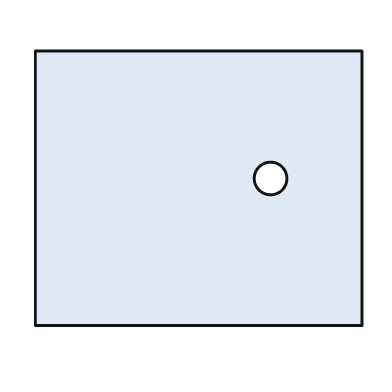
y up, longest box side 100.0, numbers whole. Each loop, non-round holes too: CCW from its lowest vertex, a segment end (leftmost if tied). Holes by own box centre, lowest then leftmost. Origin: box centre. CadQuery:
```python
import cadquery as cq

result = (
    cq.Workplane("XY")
    .moveTo(-50.0, -42.0)
    .lineTo(50.0, -42.0)
    .lineTo(50.0, 42.0)
    .lineTo(-50.0, 42.0)
    .close()
    .moveTo(22.0, 3.0)
    .circle(5.0)
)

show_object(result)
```